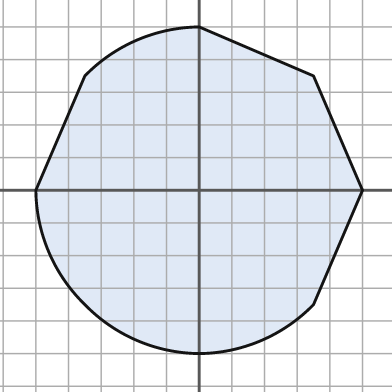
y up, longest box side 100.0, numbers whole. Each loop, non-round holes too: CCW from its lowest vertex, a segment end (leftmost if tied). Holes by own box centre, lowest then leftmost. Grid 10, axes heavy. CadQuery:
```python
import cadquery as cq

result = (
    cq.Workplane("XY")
    .moveTo(0.0, -50.0)
    .threePointArc((19.0, -46.0), (35.0, -35.0))
    .lineTo(50.0, 0.0)
    .lineTo(35.0, 35.0)
    .lineTo(0.0, 50.0)
    .threePointArc((-19.0, 46.0), (-35.0, 35.0))
    .lineTo(-50.0, 0.0)
    .threePointArc((-46.0, -19.0), (-35.0, -35.0))
    .threePointArc((-19.0, -46.0), (0.0, -50.0))
    .close()
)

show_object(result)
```